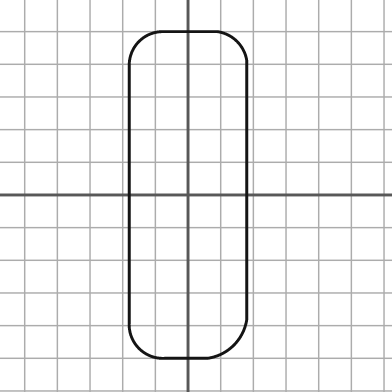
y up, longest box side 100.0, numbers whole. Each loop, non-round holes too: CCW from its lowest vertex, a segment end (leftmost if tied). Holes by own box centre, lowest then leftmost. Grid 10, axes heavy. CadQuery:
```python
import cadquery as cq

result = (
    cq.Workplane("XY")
    .moveTo(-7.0, -50.0)
    .lineTo(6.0, -50.0)
    .threePointArc((14.0, -46.0), (18.0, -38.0))
    .lineTo(18.0, 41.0)
    .threePointArc((15.0, 47.0), (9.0, 50.0))
    .lineTo(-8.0, 50.0)
    .threePointArc((-15.0, 47.0), (-18.0, 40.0))
    .lineTo(-18.0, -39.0)
    .threePointArc((-15.0, -47.0), (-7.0, -50.0))
    .close()
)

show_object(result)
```